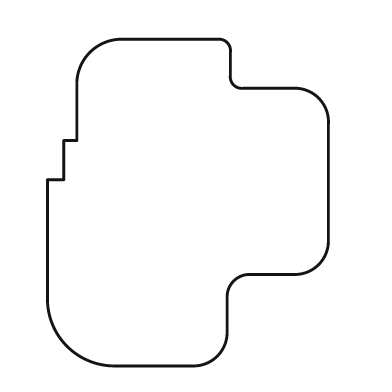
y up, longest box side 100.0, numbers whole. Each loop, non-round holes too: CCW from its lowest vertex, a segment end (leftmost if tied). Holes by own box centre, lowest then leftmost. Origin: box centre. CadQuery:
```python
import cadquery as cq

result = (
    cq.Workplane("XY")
    .moveTo(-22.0, -50.0)
    .lineTo(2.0, -50.0)
    .threePointArc((9.0, -47.0), (12.0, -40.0))
    .lineTo(12.0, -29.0)
    .threePointArc((14.0, -24.0), (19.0, -22.0))
    .lineTo(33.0, -22.0)
    .threePointArc((40.0, -19.0), (43.0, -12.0))
    .lineTo(43.0, 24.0)
    .threePointArc((40.0, 32.0), (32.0, 35.0))
    .lineTo(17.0, 35.0)
    .threePointArc((14.0, 36.0), (13.0, 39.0))
    .lineTo(13.0, 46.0)
    .threePointArc((12.0, 49.0), (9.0, 50.0))
    .lineTo(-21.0, 50.0)
    .threePointArc((-30.0, 46.0), (-34.0, 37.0))
    .lineTo(-34.0, 19.0)
    .lineTo(-38.0, 19.0)
    .lineTo(-38.0, 7.0)
    .lineTo(-43.0, 7.0)
    .lineTo(-43.0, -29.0)
    .threePointArc((-37.0, -44.0), (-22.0, -50.0))
    .close()
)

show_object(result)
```